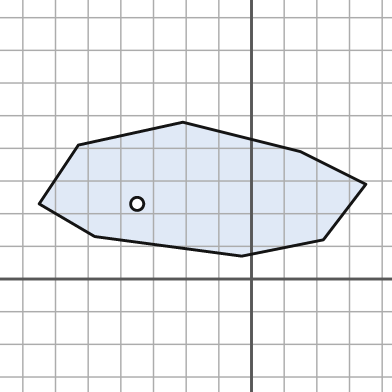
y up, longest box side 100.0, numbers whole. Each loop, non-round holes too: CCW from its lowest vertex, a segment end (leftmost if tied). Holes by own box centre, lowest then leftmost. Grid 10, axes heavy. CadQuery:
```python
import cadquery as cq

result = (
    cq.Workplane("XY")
    .moveTo(-3.0, 7.0)
    .lineTo(22.0, 12.0)
    .lineTo(35.0, 29.0)
    .lineTo(15.0, 39.0)
    .lineTo(-21.0, 48.0)
    .lineTo(-53.0, 41.0)
    .lineTo(-65.0, 23.0)
    .lineTo(-48.0, 13.0)
    .close()
    .moveTo(-35.0, 23.0)
    .circle(2.0)
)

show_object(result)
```